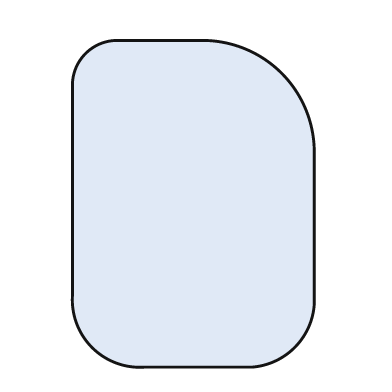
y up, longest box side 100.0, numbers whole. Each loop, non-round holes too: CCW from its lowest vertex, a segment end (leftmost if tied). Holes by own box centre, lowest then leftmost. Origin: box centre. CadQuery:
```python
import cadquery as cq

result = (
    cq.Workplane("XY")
    .moveTo(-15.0, -50.0)
    .lineTo(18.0, -50.0)
    .threePointArc((31.0, -44.0), (37.0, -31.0))
    .lineTo(37.0, 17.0)
    .threePointArc((27.0, 40.0), (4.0, 50.0))
    .lineTo(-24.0, 50.0)
    .threePointArc((-33.0, 46.0), (-37.0, 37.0))
    .lineTo(-37.0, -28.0)
    .threePointArc((-31.0, -44.0), (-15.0, -50.0))
    .close()
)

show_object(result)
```